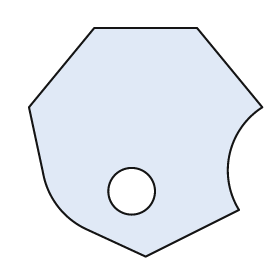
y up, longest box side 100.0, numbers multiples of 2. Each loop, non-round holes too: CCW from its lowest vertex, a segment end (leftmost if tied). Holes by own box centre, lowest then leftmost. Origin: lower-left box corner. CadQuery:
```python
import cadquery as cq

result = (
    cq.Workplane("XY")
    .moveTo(50.0, 0.0)
    .lineTo(90.0, 20.0)
    .threePointArc((86.0, 44.0), (100.0, 64.0))
    .lineTo(72.0, 98.0)
    .lineTo(28.0, 98.0)
    .lineTo(0.0, 64.0)
    .lineTo(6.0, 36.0)
    .threePointArc((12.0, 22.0), (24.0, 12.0))
    .close()
    .moveTo(44.0, 28.0)
    .circle(10.0)
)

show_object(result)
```